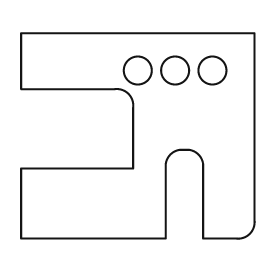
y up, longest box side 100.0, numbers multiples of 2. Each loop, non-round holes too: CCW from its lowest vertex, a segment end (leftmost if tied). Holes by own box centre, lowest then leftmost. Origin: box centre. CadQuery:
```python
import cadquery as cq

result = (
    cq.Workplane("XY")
    .moveTo(-50.0, -44.0)
    .lineTo(12.0, -44.0)
    .lineTo(12.0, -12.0)
    .threePointArc((14.0, -8.0), (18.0, -6.0))
    .lineTo(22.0, -6.0)
    .threePointArc((26.0, -8.0), (28.0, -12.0))
    .lineTo(28.0, -44.0)
    .lineTo(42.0, -44.0)
    .threePointArc((48.0, -42.0), (50.0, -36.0))
    .lineTo(50.0, 44.0)
    .lineTo(-50.0, 44.0)
    .lineTo(-50.0, 20.0)
    .lineTo(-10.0, 20.0)
    .threePointArc((-4.0, 18.0), (-2.0, 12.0))
    .lineTo(-2.0, -14.0)
    .lineTo(-50.0, -14.0)
    .close()
    .moveTo(0.0, 28.0)
    .circle(6.0)
    .moveTo(16.0, 28.0)
    .circle(6.0)
    .moveTo(32.0, 28.0)
    .circle(6.0)
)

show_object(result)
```